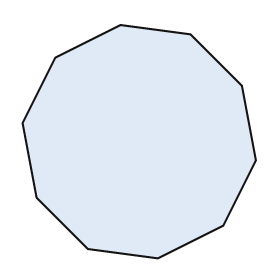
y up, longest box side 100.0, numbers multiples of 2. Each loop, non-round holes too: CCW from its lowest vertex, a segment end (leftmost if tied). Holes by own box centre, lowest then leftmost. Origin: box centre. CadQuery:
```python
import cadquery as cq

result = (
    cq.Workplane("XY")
    .moveTo(8.0, -50.0)
    .lineTo(36.0, -36.0)
    .lineTo(50.0, -8.0)
    .lineTo(44.0, 24.0)
    .lineTo(22.0, 46.0)
    .lineTo(-8.0, 50.0)
    .lineTo(-36.0, 36.0)
    .lineTo(-50.0, 8.0)
    .lineTo(-44.0, -24.0)
    .lineTo(-22.0, -46.0)
    .close()
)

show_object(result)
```